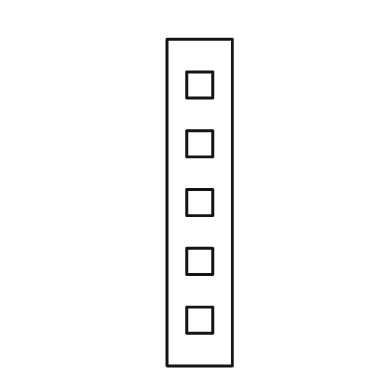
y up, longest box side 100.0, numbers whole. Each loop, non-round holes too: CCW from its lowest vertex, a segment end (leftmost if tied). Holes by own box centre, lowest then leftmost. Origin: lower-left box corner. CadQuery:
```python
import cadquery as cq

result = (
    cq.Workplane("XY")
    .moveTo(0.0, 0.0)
    .lineTo(20.0, 0.0)
    .lineTo(20.0, 100.0)
    .lineTo(0.0, 100.0)
    .close()
    .moveTo(6.0, 10.0)
    .lineTo(14.0, 10.0)
    .lineTo(14.0, 18.0)
    .lineTo(6.0, 18.0)
    .close()
    .moveTo(6.0, 28.0)
    .lineTo(14.0, 28.0)
    .lineTo(14.0, 36.0)
    .lineTo(6.0, 36.0)
    .close()
    .moveTo(6.0, 46.0)
    .lineTo(14.0, 46.0)
    .lineTo(14.0, 54.0)
    .lineTo(6.0, 54.0)
    .close()
    .moveTo(6.0, 64.0)
    .lineTo(14.0, 64.0)
    .lineTo(14.0, 72.0)
    .lineTo(6.0, 72.0)
    .close()
    .moveTo(6.0, 82.0)
    .lineTo(14.0, 82.0)
    .lineTo(14.0, 90.0)
    .lineTo(6.0, 90.0)
    .close()
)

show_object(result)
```